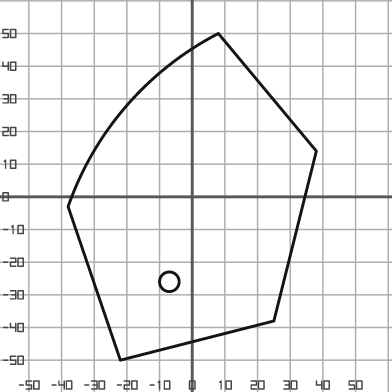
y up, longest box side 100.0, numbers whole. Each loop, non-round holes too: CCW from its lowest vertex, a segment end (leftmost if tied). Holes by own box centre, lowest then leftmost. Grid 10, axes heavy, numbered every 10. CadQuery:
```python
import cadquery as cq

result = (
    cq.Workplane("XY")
    .moveTo(-22.0, -50.0)
    .lineTo(25.0, -38.0)
    .lineTo(38.0, 14.0)
    .lineTo(8.0, 50.0)
    .threePointArc((-20.0, 28.0), (-38.0, -3.0))
    .close()
    .moveTo(-7.0, -26.0)
    .circle(3.0)
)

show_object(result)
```